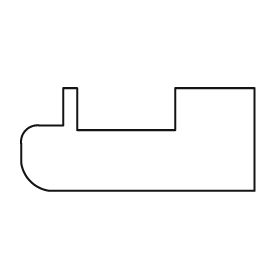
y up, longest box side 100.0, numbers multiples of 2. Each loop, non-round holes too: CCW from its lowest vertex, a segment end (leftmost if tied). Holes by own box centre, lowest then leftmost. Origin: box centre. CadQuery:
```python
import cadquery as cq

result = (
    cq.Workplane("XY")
    .moveTo(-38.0, -22.0)
    .lineTo(50.0, -22.0)
    .lineTo(50.0, 22.0)
    .lineTo(16.0, 22.0)
    .lineTo(16.0, 4.0)
    .lineTo(-26.0, 4.0)
    .lineTo(-26.0, 22.0)
    .lineTo(-32.0, 22.0)
    .lineTo(-32.0, 6.0)
    .lineTo(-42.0, 6.0)
    .threePointArc((-48.0, 4.0), (-50.0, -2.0))
    .lineTo(-50.0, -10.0)
    .threePointArc((-46.0, -18.0), (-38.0, -22.0))
    .close()
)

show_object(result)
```